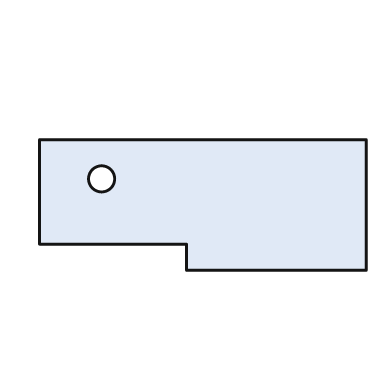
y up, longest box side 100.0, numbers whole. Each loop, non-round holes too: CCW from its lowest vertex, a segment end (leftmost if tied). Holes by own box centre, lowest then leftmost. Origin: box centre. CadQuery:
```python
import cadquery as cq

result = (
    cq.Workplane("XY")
    .moveTo(-5.0, -20.0)
    .lineTo(50.0, -20.0)
    .lineTo(50.0, 20.0)
    .lineTo(-50.0, 20.0)
    .lineTo(-50.0, -12.0)
    .lineTo(-5.0, -12.0)
    .close()
    .moveTo(-31.0, 8.0)
    .circle(4.0)
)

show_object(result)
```